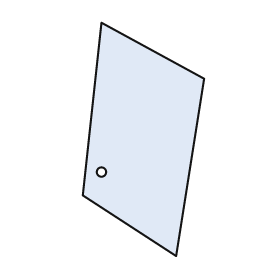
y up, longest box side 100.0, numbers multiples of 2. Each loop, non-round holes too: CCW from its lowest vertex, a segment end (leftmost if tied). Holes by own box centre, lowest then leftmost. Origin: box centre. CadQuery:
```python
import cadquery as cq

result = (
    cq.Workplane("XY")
    .moveTo(14.0, -50.0)
    .lineTo(26.0, 26.0)
    .lineTo(-18.0, 50.0)
    .lineTo(-26.0, -24.0)
    .close()
    .moveTo(-18.0, -14.0)
    .circle(2.0)
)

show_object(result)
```